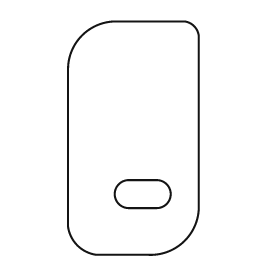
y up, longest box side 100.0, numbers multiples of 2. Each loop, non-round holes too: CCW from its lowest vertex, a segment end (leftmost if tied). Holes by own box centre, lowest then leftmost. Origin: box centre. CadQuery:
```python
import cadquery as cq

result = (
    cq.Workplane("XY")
    .moveTo(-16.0, -50.0)
    .lineTo(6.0, -50.0)
    .threePointArc((22.0, -44.0), (28.0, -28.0))
    .lineTo(28.0, 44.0)
    .threePointArc((26.0, 48.0), (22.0, 50.0))
    .lineTo(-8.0, 50.0)
    .threePointArc((-22.0, 44.0), (-28.0, 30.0))
    .lineTo(-28.0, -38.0)
    .threePointArc((-24.0, -46.0), (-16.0, -50.0))
    .close()
    .moveTo(-2.0, -30.0)
    .lineTo(10.0, -30.0)
    .threePointArc((16.0, -24.0), (10.0, -18.0))
    .lineTo(-2.0, -18.0)
    .threePointArc((-8.0, -24.0), (-2.0, -30.0))
    .close()
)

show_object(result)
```